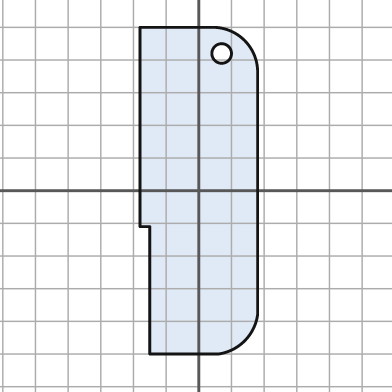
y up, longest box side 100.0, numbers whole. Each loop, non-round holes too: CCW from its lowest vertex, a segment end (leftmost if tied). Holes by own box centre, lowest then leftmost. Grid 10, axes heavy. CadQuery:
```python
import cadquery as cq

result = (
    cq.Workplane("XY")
    .moveTo(-15.0, -50.0)
    .lineTo(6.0, -50.0)
    .threePointArc((14.0, -46.0), (18.0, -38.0))
    .lineTo(18.0, 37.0)
    .threePointArc((14.0, 46.0), (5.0, 50.0))
    .lineTo(-18.0, 50.0)
    .lineTo(-18.0, -11.0)
    .lineTo(-15.0, -11.0)
    .close()
    .moveTo(7.0, 42.0)
    .circle(3.0)
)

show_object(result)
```